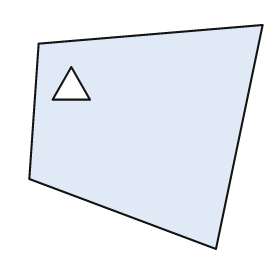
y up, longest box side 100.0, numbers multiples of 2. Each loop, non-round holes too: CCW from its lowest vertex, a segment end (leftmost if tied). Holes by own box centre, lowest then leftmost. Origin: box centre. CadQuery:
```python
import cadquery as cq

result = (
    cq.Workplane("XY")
    .moveTo(30.0, -48.0)
    .lineTo(50.0, 48.0)
    .lineTo(-46.0, 40.0)
    .lineTo(-50.0, -18.0)
    .close()
    .moveTo(-40.0, 16.0)
    .lineTo(-24.0, 16.0)
    .lineTo(-32.0, 30.0)
    .close()
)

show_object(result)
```